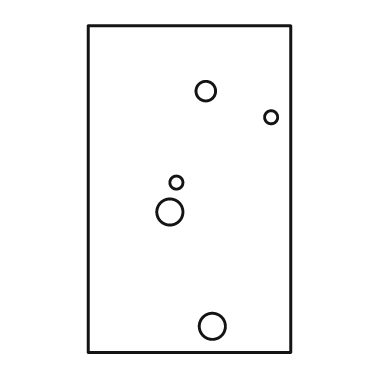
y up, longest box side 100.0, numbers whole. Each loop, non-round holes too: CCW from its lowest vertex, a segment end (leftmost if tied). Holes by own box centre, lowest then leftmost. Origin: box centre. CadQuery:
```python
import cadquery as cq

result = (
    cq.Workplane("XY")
    .moveTo(-31.0, -50.0)
    .lineTo(31.0, -50.0)
    .lineTo(31.0, 50.0)
    .lineTo(-31.0, 50.0)
    .close()
    .moveTo(7.0, -42.0)
    .circle(4.0)
    .moveTo(-6.0, -7.0)
    .circle(4.0)
    .moveTo(-4.0, 2.0)
    .circle(2.0)
    .moveTo(25.0, 22.0)
    .circle(2.0)
    .moveTo(5.0, 30.0)
    .circle(3.0)
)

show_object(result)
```